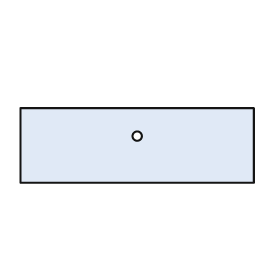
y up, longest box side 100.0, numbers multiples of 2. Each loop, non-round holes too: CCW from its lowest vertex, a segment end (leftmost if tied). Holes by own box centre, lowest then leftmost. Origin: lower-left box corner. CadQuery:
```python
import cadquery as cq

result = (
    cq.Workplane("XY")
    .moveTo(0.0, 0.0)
    .lineTo(100.0, 0.0)
    .lineTo(100.0, 32.0)
    .lineTo(0.0, 32.0)
    .close()
    .moveTo(50.0, 20.0)
    .circle(2.0)
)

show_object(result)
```